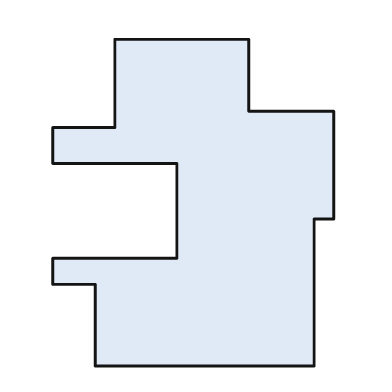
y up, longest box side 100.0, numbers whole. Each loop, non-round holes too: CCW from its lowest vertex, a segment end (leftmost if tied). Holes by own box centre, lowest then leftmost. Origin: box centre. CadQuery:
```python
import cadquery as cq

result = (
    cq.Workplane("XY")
    .moveTo(-30.0, -50.0)
    .lineTo(37.0, -50.0)
    .lineTo(37.0, -5.0)
    .lineTo(43.0, -5.0)
    .lineTo(43.0, 28.0)
    .lineTo(17.0, 28.0)
    .lineTo(17.0, 50.0)
    .lineTo(-24.0, 50.0)
    .lineTo(-24.0, 23.0)
    .lineTo(-43.0, 23.0)
    .lineTo(-43.0, 12.0)
    .lineTo(-5.0, 12.0)
    .lineTo(-5.0, -17.0)
    .lineTo(-43.0, -17.0)
    .lineTo(-43.0, -25.0)
    .lineTo(-30.0, -25.0)
    .close()
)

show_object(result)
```